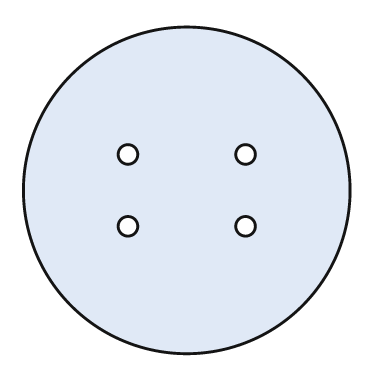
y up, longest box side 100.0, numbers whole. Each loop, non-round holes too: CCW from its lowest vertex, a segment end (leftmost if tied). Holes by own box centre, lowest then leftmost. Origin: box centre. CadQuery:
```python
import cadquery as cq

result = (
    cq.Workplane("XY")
    .moveTo(0.0, 0.0)
    .circle(50.0)
    .moveTo(-18.0, -11.0)
    .circle(3.0)
    .moveTo(18.0, -11.0)
    .circle(3.0)
    .moveTo(-18.0, 11.0)
    .circle(3.0)
    .moveTo(18.0, 11.0)
    .circle(3.0)
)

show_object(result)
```